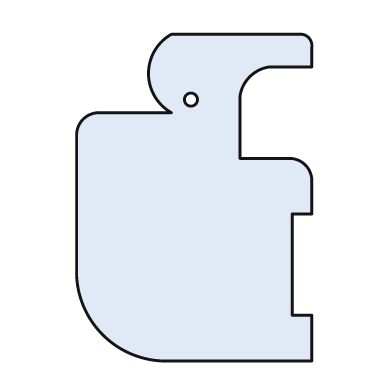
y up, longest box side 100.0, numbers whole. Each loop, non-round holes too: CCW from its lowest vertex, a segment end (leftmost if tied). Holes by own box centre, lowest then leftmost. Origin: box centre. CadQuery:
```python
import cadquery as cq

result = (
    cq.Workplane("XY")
    .moveTo(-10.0, -50.0)
    .lineTo(36.0, -50.0)
    .lineTo(36.0, -36.0)
    .lineTo(30.0, -36.0)
    .lineTo(30.0, -5.0)
    .lineTo(36.0, -5.0)
    .lineTo(36.0, 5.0)
    .threePointArc((34.0, 10.0), (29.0, 12.0))
    .lineTo(14.0, 12.0)
    .lineTo(14.0, 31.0)
    .threePointArc((17.0, 37.0), (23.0, 40.0))
    .lineTo(36.0, 40.0)
    .lineTo(36.0, 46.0)
    .threePointArc((35.0, 49.0), (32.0, 50.0))
    .lineTo(-7.0, 50.0)
    .threePointArc((-14.0, 38.0), (-7.0, 26.0))
    .lineTo(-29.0, 26.0)
    .threePointArc((-34.0, 24.0), (-36.0, 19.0))
    .lineTo(-36.0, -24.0)
    .threePointArc((-28.0, -42.0), (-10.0, -50.0))
    .close()
    .moveTo(-1.0, 30.0)
    .circle(2.0)
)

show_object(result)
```